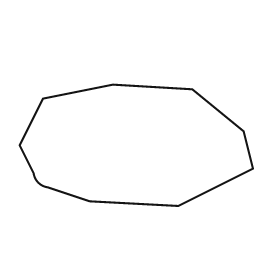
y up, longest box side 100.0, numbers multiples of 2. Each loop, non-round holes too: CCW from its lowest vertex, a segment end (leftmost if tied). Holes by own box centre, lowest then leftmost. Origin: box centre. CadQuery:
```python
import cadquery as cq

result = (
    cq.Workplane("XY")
    .moveTo(18.0, -26.0)
    .lineTo(50.0, -10.0)
    .lineTo(46.0, 6.0)
    .lineTo(24.0, 24.0)
    .lineTo(-10.0, 26.0)
    .lineTo(-40.0, 20.0)
    .lineTo(-50.0, 0.0)
    .lineTo(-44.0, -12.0)
    .threePointArc((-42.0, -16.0), (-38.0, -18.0))
    .lineTo(-20.0, -24.0)
    .close()
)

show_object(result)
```